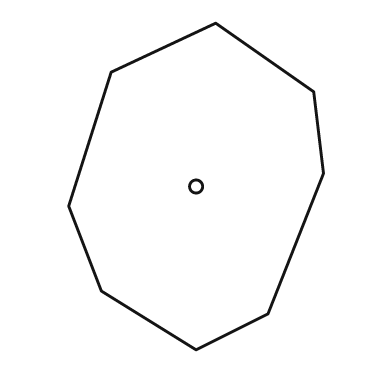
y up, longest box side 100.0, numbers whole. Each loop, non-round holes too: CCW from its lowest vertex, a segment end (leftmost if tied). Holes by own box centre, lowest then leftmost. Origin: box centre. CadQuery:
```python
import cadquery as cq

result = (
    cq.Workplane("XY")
    .moveTo(0.0, -50.0)
    .lineTo(22.0, -39.0)
    .lineTo(39.0, 4.0)
    .lineTo(36.0, 29.0)
    .lineTo(6.0, 50.0)
    .lineTo(-26.0, 35.0)
    .lineTo(-39.0, -6.0)
    .lineTo(-29.0, -32.0)
    .close()
    .moveTo(0.0, 0.0)
    .circle(2.0)
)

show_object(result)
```